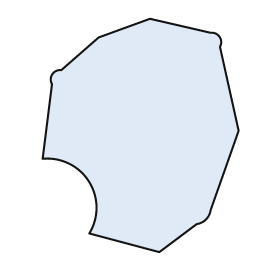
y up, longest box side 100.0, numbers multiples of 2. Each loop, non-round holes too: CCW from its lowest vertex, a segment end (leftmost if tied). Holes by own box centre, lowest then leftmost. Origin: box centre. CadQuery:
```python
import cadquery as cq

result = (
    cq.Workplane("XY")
    .moveTo(8.0, -50.0)
    .lineTo(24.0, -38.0)
    .threePointArc((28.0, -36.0), (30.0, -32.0))
    .lineTo(42.0, 2.0)
    .lineTo(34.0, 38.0)
    .threePointArc((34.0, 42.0), (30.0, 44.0))
    .lineTo(4.0, 50.0)
    .lineTo(-18.0, 42.0)
    .lineTo(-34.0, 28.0)
    .threePointArc((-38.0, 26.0), (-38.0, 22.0))
    .lineTo(-42.0, -10.0)
    .threePointArc((-22.0, -20.0), (-22.0, -42.0))
    .close()
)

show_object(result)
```